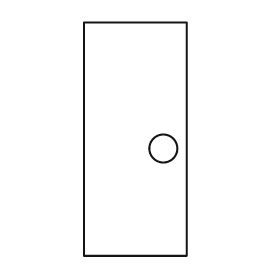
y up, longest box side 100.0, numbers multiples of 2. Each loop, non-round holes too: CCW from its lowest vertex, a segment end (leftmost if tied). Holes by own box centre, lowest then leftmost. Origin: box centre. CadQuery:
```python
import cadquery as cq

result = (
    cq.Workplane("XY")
    .moveTo(-22.0, -50.0)
    .lineTo(22.0, -50.0)
    .lineTo(22.0, 50.0)
    .lineTo(-22.0, 50.0)
    .close()
    .moveTo(12.0, -4.0)
    .circle(6.0)
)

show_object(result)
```